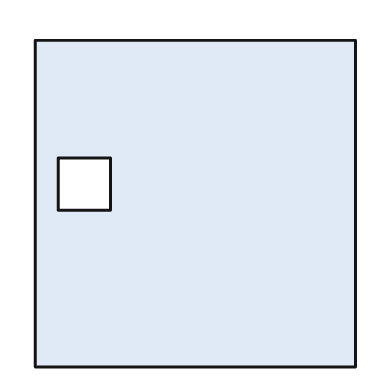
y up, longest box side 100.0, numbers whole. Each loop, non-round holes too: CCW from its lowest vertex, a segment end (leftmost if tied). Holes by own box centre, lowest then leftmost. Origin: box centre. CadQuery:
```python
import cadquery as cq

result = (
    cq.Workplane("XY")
    .moveTo(-49.0, -50.0)
    .lineTo(49.0, -50.0)
    .lineTo(49.0, 50.0)
    .lineTo(-49.0, 50.0)
    .close()
    .moveTo(-42.0, -2.0)
    .lineTo(-26.0, -2.0)
    .lineTo(-26.0, 14.0)
    .lineTo(-42.0, 14.0)
    .close()
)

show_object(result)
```